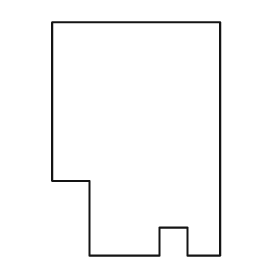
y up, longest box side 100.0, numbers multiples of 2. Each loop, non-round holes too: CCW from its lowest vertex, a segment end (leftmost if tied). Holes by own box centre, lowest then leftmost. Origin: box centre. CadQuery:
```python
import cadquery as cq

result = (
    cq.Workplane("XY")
    .moveTo(-20.0, -50.0)
    .lineTo(10.0, -50.0)
    .lineTo(10.0, -38.0)
    .lineTo(22.0, -38.0)
    .lineTo(22.0, -50.0)
    .lineTo(36.0, -50.0)
    .lineTo(36.0, 50.0)
    .lineTo(-36.0, 50.0)
    .lineTo(-36.0, -18.0)
    .lineTo(-20.0, -18.0)
    .close()
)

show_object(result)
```